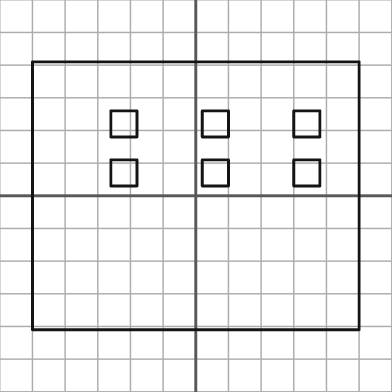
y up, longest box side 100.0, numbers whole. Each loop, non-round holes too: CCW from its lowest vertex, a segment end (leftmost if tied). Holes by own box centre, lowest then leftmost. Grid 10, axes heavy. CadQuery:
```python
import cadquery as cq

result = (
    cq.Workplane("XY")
    .moveTo(-50.0, -41.0)
    .lineTo(50.0, -41.0)
    .lineTo(50.0, 41.0)
    .lineTo(-50.0, 41.0)
    .close()
    .moveTo(-26.0, 3.0)
    .lineTo(-18.0, 3.0)
    .lineTo(-18.0, 11.0)
    .lineTo(-26.0, 11.0)
    .close()
    .moveTo(2.0, 3.0)
    .lineTo(10.0, 3.0)
    .lineTo(10.0, 11.0)
    .lineTo(2.0, 11.0)
    .close()
    .moveTo(30.0, 3.0)
    .lineTo(38.0, 3.0)
    .lineTo(38.0, 11.0)
    .lineTo(30.0, 11.0)
    .close()
    .moveTo(-26.0, 18.0)
    .lineTo(-18.0, 18.0)
    .lineTo(-18.0, 26.0)
    .lineTo(-26.0, 26.0)
    .close()
    .moveTo(2.0, 18.0)
    .lineTo(10.0, 18.0)
    .lineTo(10.0, 26.0)
    .lineTo(2.0, 26.0)
    .close()
    .moveTo(30.0, 18.0)
    .lineTo(38.0, 18.0)
    .lineTo(38.0, 26.0)
    .lineTo(30.0, 26.0)
    .close()
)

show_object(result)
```